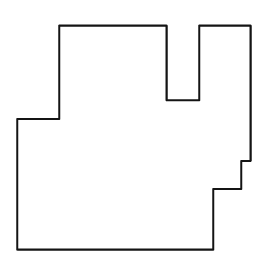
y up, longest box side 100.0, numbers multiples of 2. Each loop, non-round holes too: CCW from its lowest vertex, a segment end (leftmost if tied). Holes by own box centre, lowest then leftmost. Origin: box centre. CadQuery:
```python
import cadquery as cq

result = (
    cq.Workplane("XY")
    .moveTo(-50.0, -48.0)
    .lineTo(34.0, -48.0)
    .lineTo(34.0, -22.0)
    .lineTo(46.0, -22.0)
    .lineTo(46.0, -10.0)
    .lineTo(50.0, -10.0)
    .lineTo(50.0, 48.0)
    .lineTo(28.0, 48.0)
    .lineTo(28.0, 16.0)
    .lineTo(14.0, 16.0)
    .lineTo(14.0, 48.0)
    .lineTo(-32.0, 48.0)
    .lineTo(-32.0, 8.0)
    .lineTo(-50.0, 8.0)
    .close()
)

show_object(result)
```